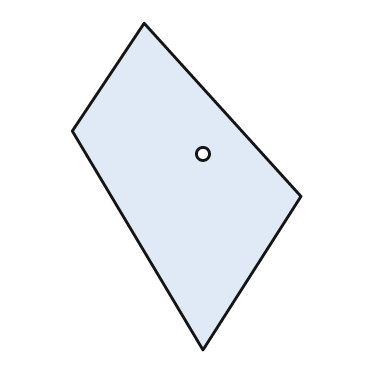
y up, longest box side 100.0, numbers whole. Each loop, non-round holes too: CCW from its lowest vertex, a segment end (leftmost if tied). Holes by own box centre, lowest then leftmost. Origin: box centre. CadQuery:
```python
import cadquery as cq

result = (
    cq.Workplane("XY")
    .moveTo(5.0, -50.0)
    .lineTo(35.0, -3.0)
    .lineTo(-13.0, 50.0)
    .lineTo(-35.0, 17.0)
    .close()
    .moveTo(5.0, 10.0)
    .circle(2.0)
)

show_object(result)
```